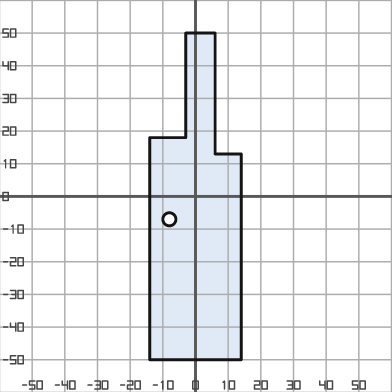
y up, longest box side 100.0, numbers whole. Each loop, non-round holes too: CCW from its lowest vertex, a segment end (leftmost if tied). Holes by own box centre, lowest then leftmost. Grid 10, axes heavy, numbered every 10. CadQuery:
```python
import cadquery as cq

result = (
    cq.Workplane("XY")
    .moveTo(-14.0, -50.0)
    .lineTo(14.0, -50.0)
    .lineTo(14.0, 13.0)
    .lineTo(6.0, 13.0)
    .lineTo(6.0, 50.0)
    .lineTo(-3.0, 50.0)
    .lineTo(-3.0, 18.0)
    .lineTo(-14.0, 18.0)
    .close()
    .moveTo(-8.0, -7.0)
    .circle(2.0)
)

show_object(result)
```